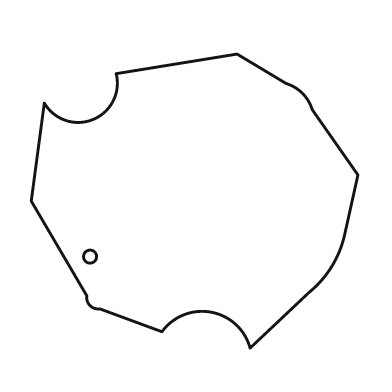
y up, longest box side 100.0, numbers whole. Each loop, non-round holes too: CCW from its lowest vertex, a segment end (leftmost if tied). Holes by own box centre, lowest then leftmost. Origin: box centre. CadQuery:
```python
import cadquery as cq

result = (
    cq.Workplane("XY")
    .moveTo(17.0, -45.0)
    .lineTo(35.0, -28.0)
    .threePointArc((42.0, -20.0), (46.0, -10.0))
    .lineTo(50.0, 8.0)
    .lineTo(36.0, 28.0)
    .threePointArc((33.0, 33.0), (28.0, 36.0))
    .lineTo(13.0, 45.0)
    .lineTo(-24.0, 39.0)
    .threePointArc((-31.0, 25.0), (-46.0, 30.0))
    .lineTo(-50.0, 0.0)
    .lineTo(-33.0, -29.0)
    .threePointArc((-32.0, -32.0), (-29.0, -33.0))
    .lineTo(-10.0, -40.0)
    .threePointArc((5.0, -34.0), (17.0, -45.0))
    .close()
    .moveTo(-32.0, -17.0)
    .circle(2.0)
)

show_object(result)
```